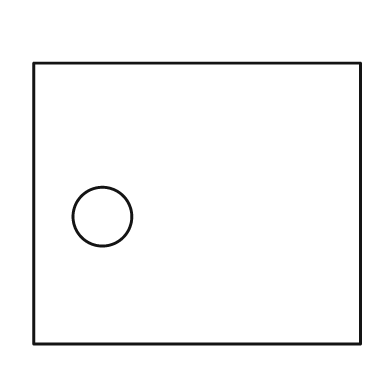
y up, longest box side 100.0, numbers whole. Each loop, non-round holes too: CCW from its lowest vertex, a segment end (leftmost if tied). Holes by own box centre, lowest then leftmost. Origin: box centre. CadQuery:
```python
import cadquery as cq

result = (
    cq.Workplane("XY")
    .moveTo(-50.0, -43.0)
    .lineTo(50.0, -43.0)
    .lineTo(50.0, 43.0)
    .lineTo(-50.0, 43.0)
    .close()
    .moveTo(-29.0, -4.0)
    .circle(9.0)
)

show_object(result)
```